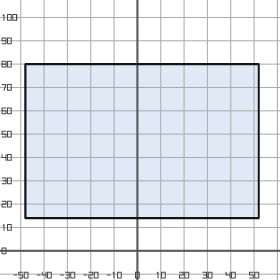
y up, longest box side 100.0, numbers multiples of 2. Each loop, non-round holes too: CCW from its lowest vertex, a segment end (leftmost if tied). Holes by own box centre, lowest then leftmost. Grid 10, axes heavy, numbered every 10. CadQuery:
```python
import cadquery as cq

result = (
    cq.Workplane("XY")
    .moveTo(-48.0, 14.0)
    .lineTo(52.0, 14.0)
    .lineTo(52.0, 80.0)
    .lineTo(-48.0, 80.0)
    .close()
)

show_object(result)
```